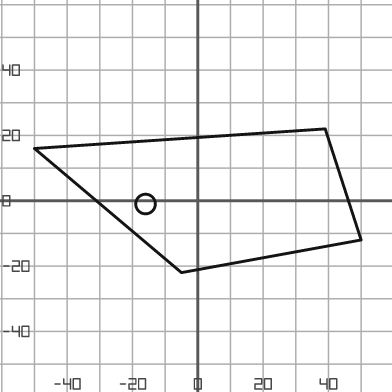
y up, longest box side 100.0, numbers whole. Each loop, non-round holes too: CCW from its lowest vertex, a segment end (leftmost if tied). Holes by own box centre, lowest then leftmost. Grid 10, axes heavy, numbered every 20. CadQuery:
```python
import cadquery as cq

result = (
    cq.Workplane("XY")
    .moveTo(-5.0, -22.0)
    .lineTo(50.0, -12.0)
    .lineTo(39.0, 22.0)
    .lineTo(-50.0, 16.0)
    .close()
    .moveTo(-16.0, -1.0)
    .circle(3.0)
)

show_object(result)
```